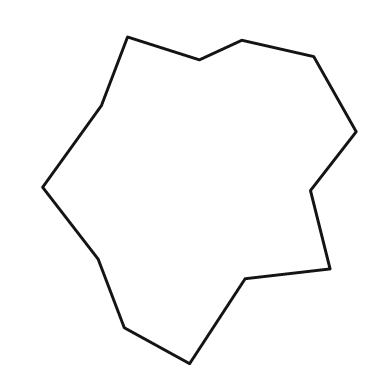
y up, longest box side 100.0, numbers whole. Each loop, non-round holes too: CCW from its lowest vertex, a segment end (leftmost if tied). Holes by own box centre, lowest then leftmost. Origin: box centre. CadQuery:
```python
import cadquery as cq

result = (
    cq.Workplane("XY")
    .moveTo(-3.0, -50.0)
    .lineTo(14.0, -24.0)
    .lineTo(40.0, -21.0)
    .lineTo(34.0, 3.0)
    .lineTo(48.0, 21.0)
    .lineTo(35.0, 44.0)
    .lineTo(13.0, 49.0)
    .lineTo(0.0, 43.0)
    .lineTo(-22.0, 50.0)
    .lineTo(-30.0, 29.0)
    .lineTo(-48.0, 4.0)
    .lineTo(-31.0, -18.0)
    .lineTo(-23.0, -39.0)
    .close()
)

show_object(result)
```